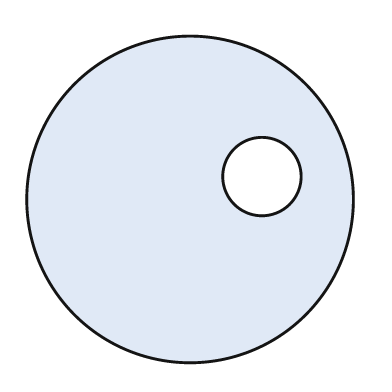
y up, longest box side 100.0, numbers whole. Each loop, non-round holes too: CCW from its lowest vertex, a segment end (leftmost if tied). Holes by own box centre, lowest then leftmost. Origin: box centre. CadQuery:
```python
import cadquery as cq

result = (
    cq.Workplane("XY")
    .moveTo(0.0, 0.0)
    .circle(50.0)
    .moveTo(22.0, 7.0)
    .circle(12.0)
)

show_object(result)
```